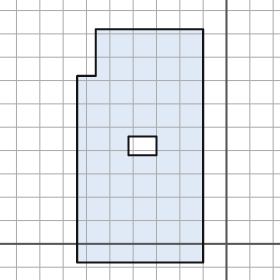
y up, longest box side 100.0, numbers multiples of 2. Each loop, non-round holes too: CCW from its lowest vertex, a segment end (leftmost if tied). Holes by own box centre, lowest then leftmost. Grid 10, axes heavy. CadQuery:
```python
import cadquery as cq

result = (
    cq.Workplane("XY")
    .moveTo(-64.0, -8.0)
    .lineTo(-10.0, -8.0)
    .lineTo(-10.0, 92.0)
    .lineTo(-56.0, 92.0)
    .lineTo(-56.0, 72.0)
    .lineTo(-64.0, 72.0)
    .close()
    .moveTo(-42.0, 38.0)
    .lineTo(-30.0, 38.0)
    .lineTo(-30.0, 46.0)
    .lineTo(-42.0, 46.0)
    .close()
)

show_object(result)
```